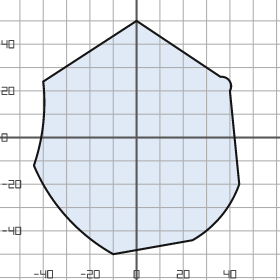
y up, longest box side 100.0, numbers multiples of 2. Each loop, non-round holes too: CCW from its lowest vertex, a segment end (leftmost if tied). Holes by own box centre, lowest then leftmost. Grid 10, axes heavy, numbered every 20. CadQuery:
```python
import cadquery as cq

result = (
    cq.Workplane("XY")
    .moveTo(-10.0, -50.0)
    .lineTo(24.0, -44.0)
    .threePointArc((36.0, -34.0), (44.0, -20.0))
    .lineTo(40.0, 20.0)
    .threePointArc((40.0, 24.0), (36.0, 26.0))
    .lineTo(0.0, 50.0)
    .lineTo(-40.0, 24.0)
    .threePointArc((-40.0, 6.0), (-44.0, -12.0))
    .threePointArc((-30.0, -34.0), (-10.0, -50.0))
    .close()
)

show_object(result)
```